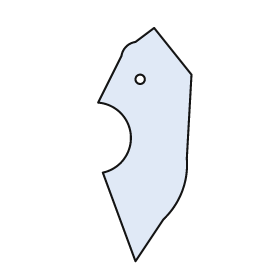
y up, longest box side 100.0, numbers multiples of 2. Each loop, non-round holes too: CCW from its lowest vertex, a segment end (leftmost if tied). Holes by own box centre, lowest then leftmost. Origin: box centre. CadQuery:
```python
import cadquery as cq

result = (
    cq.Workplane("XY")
    .moveTo(-4.0, -50.0)
    .lineTo(8.0, -32.0)
    .threePointArc((16.0, -20.0), (18.0, -6.0))
    .lineTo(20.0, 30.0)
    .lineTo(4.0, 50.0)
    .lineTo(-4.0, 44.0)
    .threePointArc((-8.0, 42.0), (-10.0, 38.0))
    .lineTo(-20.0, 18.0)
    .threePointArc((-6.0, 4.0), (-18.0, -12.0))
    .close()
    .moveTo(-2.0, 28.0)
    .circle(2.0)
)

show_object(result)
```